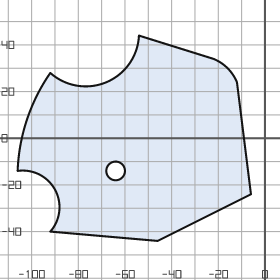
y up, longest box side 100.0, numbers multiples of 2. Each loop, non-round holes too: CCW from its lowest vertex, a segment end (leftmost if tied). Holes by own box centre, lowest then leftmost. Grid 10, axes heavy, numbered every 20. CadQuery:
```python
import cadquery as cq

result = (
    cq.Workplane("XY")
    .moveTo(-46.0, -44.0)
    .lineTo(-6.0, -24.0)
    .lineTo(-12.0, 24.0)
    .threePointArc((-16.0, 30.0), (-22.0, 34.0))
    .lineTo(-54.0, 44.0)
    .threePointArc((-68.0, 24.0), (-92.0, 28.0))
    .threePointArc((-102.0, 8.0), (-106.0, -14.0))
    .threePointArc((-90.0, -22.0), (-92.0, -40.0))
    .close()
    .moveTo(-64.0, -14.0)
    .circle(4.0)
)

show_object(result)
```